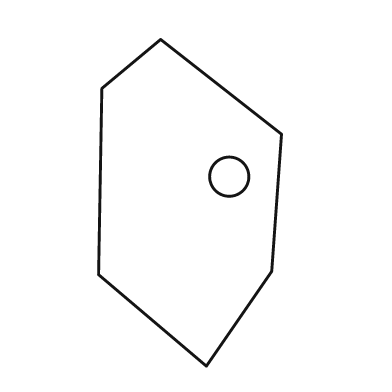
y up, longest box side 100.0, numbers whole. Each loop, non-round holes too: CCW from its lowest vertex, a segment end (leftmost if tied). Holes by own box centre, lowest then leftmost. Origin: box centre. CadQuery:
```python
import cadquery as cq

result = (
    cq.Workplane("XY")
    .moveTo(5.0, -50.0)
    .lineTo(25.0, -21.0)
    .lineTo(28.0, 21.0)
    .lineTo(-9.0, 50.0)
    .lineTo(-27.0, 35.0)
    .lineTo(-28.0, -22.0)
    .close()
    .moveTo(12.0, 8.0)
    .circle(6.0)
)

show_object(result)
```